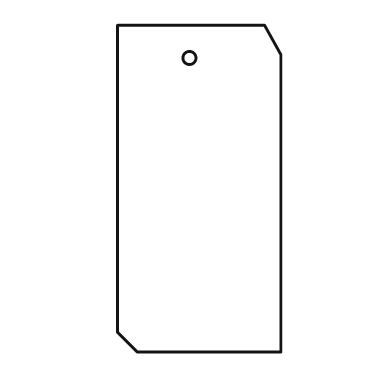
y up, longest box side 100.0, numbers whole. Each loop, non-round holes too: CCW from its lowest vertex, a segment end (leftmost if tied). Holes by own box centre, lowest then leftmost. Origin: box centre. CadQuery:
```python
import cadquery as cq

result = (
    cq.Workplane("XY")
    .moveTo(-19.0, -50.0)
    .lineTo(25.0, -50.0)
    .lineTo(25.0, 41.0)
    .lineTo(20.0, 50.0)
    .lineTo(-25.0, 50.0)
    .lineTo(-25.0, -44.0)
    .close()
    .moveTo(-3.0, 40.0)
    .circle(2.0)
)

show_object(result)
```